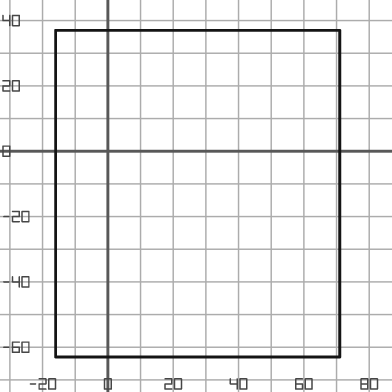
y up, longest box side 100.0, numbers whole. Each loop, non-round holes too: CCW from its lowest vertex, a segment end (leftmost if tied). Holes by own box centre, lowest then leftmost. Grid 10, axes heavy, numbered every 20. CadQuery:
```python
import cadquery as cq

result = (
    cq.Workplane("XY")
    .moveTo(-16.0, -63.0)
    .lineTo(71.0, -63.0)
    .lineTo(71.0, 37.0)
    .lineTo(-16.0, 37.0)
    .close()
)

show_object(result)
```